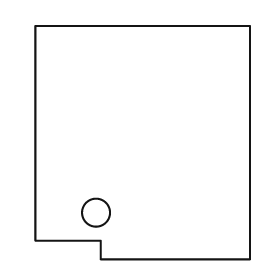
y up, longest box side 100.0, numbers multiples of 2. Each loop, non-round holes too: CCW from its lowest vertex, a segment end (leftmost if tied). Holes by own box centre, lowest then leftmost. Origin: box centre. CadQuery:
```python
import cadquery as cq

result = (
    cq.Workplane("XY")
    .moveTo(-18.0, -50.0)
    .lineTo(46.0, -50.0)
    .lineTo(46.0, 50.0)
    .lineTo(-46.0, 50.0)
    .lineTo(-46.0, -42.0)
    .lineTo(-18.0, -42.0)
    .close()
    .moveTo(-20.0, -30.0)
    .circle(6.0)
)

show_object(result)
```